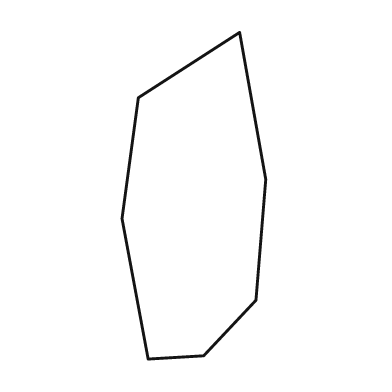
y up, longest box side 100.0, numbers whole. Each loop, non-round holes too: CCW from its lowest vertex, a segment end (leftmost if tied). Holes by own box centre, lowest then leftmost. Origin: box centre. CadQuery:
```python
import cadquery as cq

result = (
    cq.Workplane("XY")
    .moveTo(-14.0, -50.0)
    .lineTo(3.0, -49.0)
    .lineTo(19.0, -32.0)
    .lineTo(22.0, 5.0)
    .lineTo(14.0, 50.0)
    .lineTo(-17.0, 30.0)
    .lineTo(-22.0, -7.0)
    .close()
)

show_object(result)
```